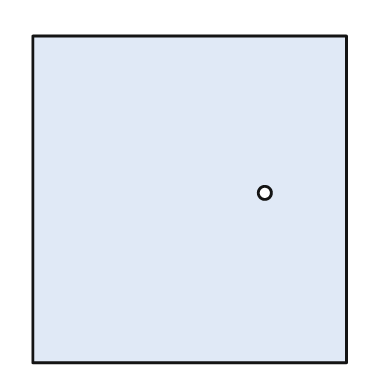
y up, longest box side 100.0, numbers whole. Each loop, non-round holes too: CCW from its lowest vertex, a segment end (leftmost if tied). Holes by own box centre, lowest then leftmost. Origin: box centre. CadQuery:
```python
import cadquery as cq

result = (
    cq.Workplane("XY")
    .moveTo(-48.0, -50.0)
    .lineTo(48.0, -50.0)
    .lineTo(48.0, 50.0)
    .lineTo(-48.0, 50.0)
    .close()
    .moveTo(23.0, 2.0)
    .circle(2.0)
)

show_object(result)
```